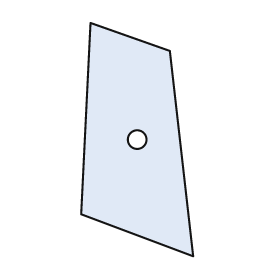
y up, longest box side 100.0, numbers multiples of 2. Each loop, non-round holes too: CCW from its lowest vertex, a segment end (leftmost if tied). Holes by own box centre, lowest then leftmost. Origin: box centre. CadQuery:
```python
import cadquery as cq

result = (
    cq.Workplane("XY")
    .moveTo(24.0, -50.0)
    .lineTo(14.0, 38.0)
    .lineTo(-20.0, 50.0)
    .lineTo(-24.0, -32.0)
    .close()
    .moveTo(0.0, 0.0)
    .circle(4.0)
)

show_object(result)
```